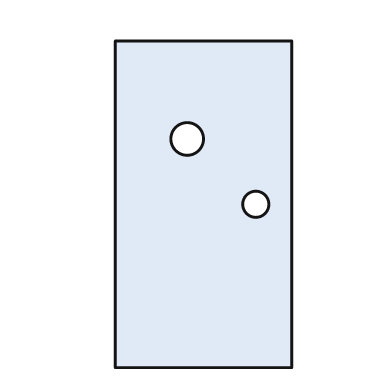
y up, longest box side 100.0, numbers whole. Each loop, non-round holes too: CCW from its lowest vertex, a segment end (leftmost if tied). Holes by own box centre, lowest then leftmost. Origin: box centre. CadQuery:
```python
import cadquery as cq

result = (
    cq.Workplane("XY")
    .moveTo(-27.0, -50.0)
    .lineTo(27.0, -50.0)
    .lineTo(27.0, 50.0)
    .lineTo(-27.0, 50.0)
    .close()
    .moveTo(16.0, 0.0)
    .circle(4.0)
    .moveTo(-5.0, 20.0)
    .circle(5.0)
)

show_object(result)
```